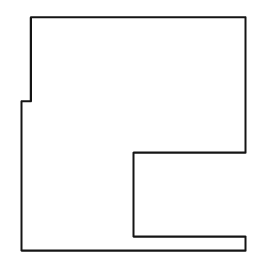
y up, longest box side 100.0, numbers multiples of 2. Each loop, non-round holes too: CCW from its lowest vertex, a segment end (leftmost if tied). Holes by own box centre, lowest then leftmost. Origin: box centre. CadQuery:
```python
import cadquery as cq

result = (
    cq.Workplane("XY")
    .moveTo(-48.0, -50.0)
    .lineTo(48.0, -50.0)
    .lineTo(48.0, -44.0)
    .lineTo(0.0, -44.0)
    .lineTo(0.0, -8.0)
    .lineTo(48.0, -8.0)
    .lineTo(48.0, 50.0)
    .lineTo(-44.0, 50.0)
    .lineTo(-44.0, 14.0)
    .lineTo(-48.0, 14.0)
    .close()
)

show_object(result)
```